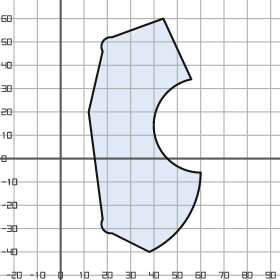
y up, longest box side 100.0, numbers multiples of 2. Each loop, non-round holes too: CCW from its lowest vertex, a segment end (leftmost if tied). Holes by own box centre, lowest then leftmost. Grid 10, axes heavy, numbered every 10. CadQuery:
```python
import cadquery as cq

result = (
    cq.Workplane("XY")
    .moveTo(38.0, -40.0)
    .threePointArc((54.0, -26.0), (60.0, -6.0))
    .threePointArc((40.0, 12.0), (56.0, 34.0))
    .lineTo(44.0, 60.0)
    .lineTo(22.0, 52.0)
    .threePointArc((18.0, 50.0), (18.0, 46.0))
    .lineTo(12.0, 20.0)
    .lineTo(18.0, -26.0)
    .threePointArc((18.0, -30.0), (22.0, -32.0))
    .close()
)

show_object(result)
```